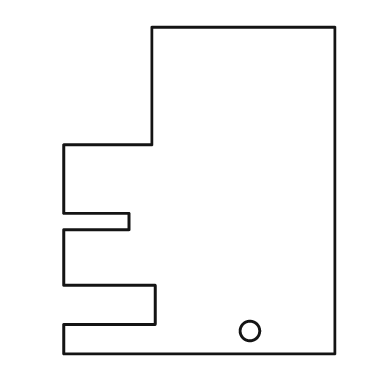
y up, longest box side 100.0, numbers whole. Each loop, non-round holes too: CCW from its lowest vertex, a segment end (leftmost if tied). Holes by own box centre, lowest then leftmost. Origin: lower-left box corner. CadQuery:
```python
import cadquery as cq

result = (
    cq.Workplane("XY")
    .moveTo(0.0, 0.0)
    .lineTo(83.0, 0.0)
    .lineTo(83.0, 100.0)
    .lineTo(27.0, 100.0)
    .lineTo(27.0, 64.0)
    .lineTo(0.0, 64.0)
    .lineTo(0.0, 43.0)
    .lineTo(20.0, 43.0)
    .lineTo(20.0, 38.0)
    .lineTo(0.0, 38.0)
    .lineTo(0.0, 21.0)
    .lineTo(28.0, 21.0)
    .lineTo(28.0, 9.0)
    .lineTo(0.0, 9.0)
    .close()
    .moveTo(57.0, 7.0)
    .circle(3.0)
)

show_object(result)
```